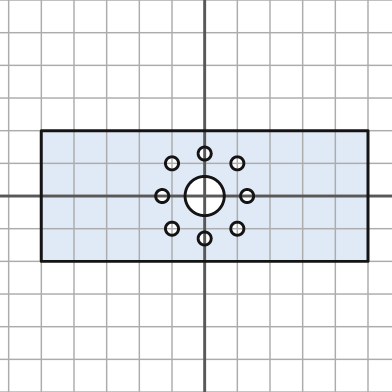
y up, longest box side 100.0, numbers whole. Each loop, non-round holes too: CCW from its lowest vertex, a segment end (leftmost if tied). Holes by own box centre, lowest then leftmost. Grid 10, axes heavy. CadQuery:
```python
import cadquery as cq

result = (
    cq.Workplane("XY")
    .moveTo(-50.0, -20.0)
    .lineTo(50.0, -20.0)
    .lineTo(50.0, 20.0)
    .lineTo(-50.0, 20.0)
    .close()
    .moveTo(0.0, -13.0)
    .circle(2.0)
    .moveTo(-10.0, -10.0)
    .circle(2.0)
    .moveTo(10.0, -10.0)
    .circle(2.0)
    .moveTo(-13.0, 0.0)
    .circle(2.0)
    .moveTo(0.0, 0.0)
    .circle(6.0)
    .moveTo(13.0, 0.0)
    .circle(2.0)
    .moveTo(-10.0, 10.0)
    .circle(2.0)
    .moveTo(10.0, 10.0)
    .circle(2.0)
    .moveTo(0.0, 13.0)
    .circle(2.0)
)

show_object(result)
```